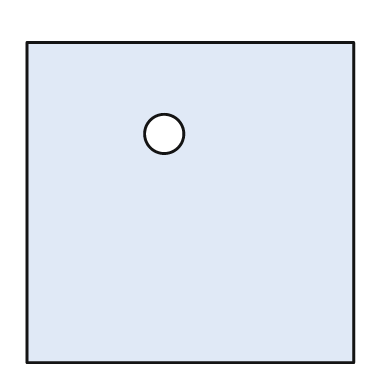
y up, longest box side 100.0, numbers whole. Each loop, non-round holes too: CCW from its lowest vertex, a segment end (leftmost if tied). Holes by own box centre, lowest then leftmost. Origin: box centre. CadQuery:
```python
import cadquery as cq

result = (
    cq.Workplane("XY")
    .moveTo(-50.0, -49.0)
    .lineTo(50.0, -49.0)
    .lineTo(50.0, 49.0)
    .lineTo(-50.0, 49.0)
    .close()
    .moveTo(-8.0, 21.0)
    .circle(6.0)
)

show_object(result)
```